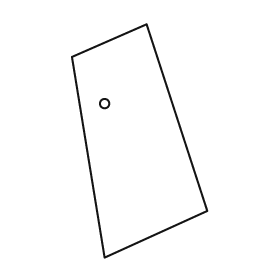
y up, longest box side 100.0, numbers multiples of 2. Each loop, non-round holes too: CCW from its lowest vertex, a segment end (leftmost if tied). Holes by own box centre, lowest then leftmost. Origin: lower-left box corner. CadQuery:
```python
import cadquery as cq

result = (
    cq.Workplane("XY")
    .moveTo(14.0, 0.0)
    .lineTo(58.0, 20.0)
    .lineTo(32.0, 100.0)
    .lineTo(0.0, 86.0)
    .close()
    .moveTo(14.0, 66.0)
    .circle(2.0)
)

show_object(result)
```